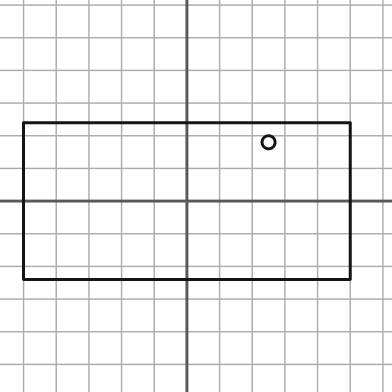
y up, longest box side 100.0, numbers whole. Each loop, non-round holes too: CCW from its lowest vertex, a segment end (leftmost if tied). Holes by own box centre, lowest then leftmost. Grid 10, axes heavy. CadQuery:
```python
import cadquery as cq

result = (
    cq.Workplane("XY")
    .moveTo(-50.0, -24.0)
    .lineTo(50.0, -24.0)
    .lineTo(50.0, 24.0)
    .lineTo(-50.0, 24.0)
    .close()
    .moveTo(25.0, 18.0)
    .circle(2.0)
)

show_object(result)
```